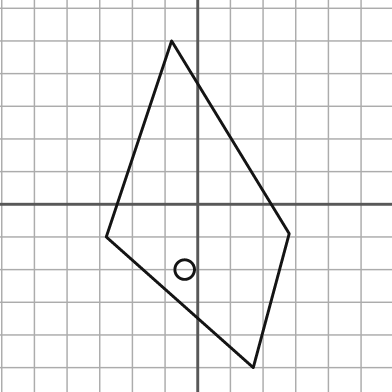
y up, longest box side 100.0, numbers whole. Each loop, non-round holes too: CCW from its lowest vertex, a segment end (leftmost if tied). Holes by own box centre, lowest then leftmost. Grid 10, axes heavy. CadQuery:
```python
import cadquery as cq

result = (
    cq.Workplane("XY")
    .moveTo(17.0, -50.0)
    .lineTo(28.0, -9.0)
    .lineTo(-8.0, 50.0)
    .lineTo(-28.0, -10.0)
    .close()
    .moveTo(-4.0, -20.0)
    .circle(3.0)
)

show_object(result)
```